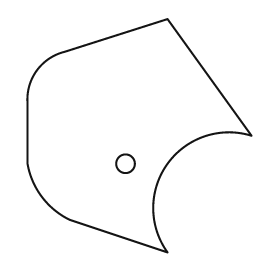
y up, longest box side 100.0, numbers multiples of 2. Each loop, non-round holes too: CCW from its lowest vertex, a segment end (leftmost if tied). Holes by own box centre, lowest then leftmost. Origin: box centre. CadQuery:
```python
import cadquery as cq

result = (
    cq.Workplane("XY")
    .moveTo(12.0, -50.0)
    .threePointArc((12.0, -12.0), (48.0, 0.0))
    .lineTo(12.0, 50.0)
    .lineTo(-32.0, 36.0)
    .threePointArc((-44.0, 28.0), (-48.0, 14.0))
    .lineTo(-48.0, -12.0)
    .threePointArc((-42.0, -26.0), (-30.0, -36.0))
    .close()
    .moveTo(-6.0, -12.0)
    .circle(4.0)
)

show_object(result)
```